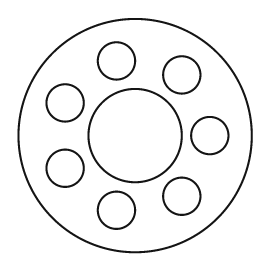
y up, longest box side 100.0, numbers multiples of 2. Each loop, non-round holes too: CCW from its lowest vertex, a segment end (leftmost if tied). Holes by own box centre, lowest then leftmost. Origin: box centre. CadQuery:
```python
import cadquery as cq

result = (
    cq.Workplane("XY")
    .moveTo(0.0, 0.0)
    .circle(50.0)
    .moveTo(-8.0, -32.0)
    .circle(8.0)
    .moveTo(20.0, -26.0)
    .circle(8.0)
    .moveTo(-30.0, -14.0)
    .circle(8.0)
    .moveTo(0.0, 0.0)
    .circle(20.0)
    .moveTo(32.0, 0.0)
    .circle(8.0)
    .moveTo(-30.0, 14.0)
    .circle(8.0)
    .moveTo(20.0, 26.0)
    .circle(8.0)
    .moveTo(-8.0, 32.0)
    .circle(8.0)
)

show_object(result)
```